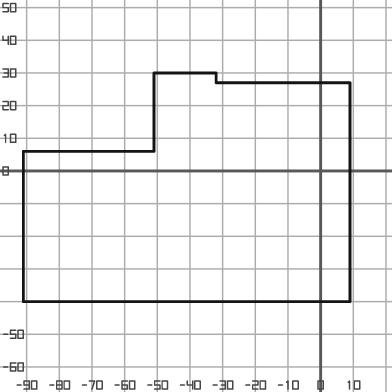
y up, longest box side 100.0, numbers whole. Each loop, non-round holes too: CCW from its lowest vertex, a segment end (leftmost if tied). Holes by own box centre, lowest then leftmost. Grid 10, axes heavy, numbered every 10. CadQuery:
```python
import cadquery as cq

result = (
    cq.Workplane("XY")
    .moveTo(-91.0, -40.0)
    .lineTo(9.0, -40.0)
    .lineTo(9.0, 27.0)
    .lineTo(-32.0, 27.0)
    .lineTo(-32.0, 30.0)
    .lineTo(-51.0, 30.0)
    .lineTo(-51.0, 6.0)
    .lineTo(-91.0, 6.0)
    .close()
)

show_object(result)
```